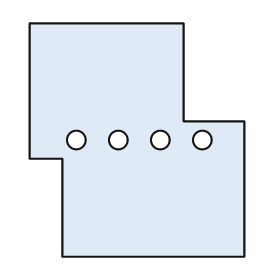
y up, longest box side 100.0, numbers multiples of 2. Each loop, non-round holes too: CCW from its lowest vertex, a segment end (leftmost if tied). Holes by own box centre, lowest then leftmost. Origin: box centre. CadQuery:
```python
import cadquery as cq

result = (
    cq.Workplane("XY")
    .moveTo(-32.0, -50.0)
    .lineTo(46.0, -50.0)
    .lineTo(46.0, 8.0)
    .lineTo(20.0, 8.0)
    .lineTo(20.0, 50.0)
    .lineTo(-46.0, 50.0)
    .lineTo(-46.0, -8.0)
    .lineTo(-32.0, -8.0)
    .close()
    .moveTo(-26.0, 0.0)
    .circle(4.0)
    .moveTo(-8.0, 0.0)
    .circle(4.0)
    .moveTo(10.0, 0.0)
    .circle(4.0)
    .moveTo(28.0, 0.0)
    .circle(4.0)
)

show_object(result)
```